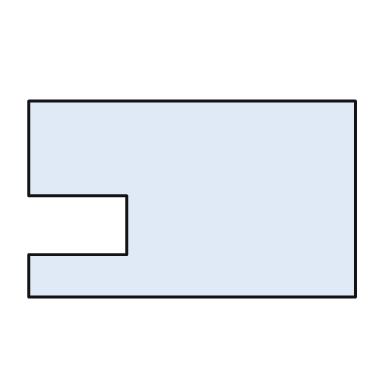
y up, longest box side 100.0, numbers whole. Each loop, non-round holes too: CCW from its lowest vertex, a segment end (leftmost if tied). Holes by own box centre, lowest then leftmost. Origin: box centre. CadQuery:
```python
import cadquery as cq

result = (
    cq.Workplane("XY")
    .moveTo(-50.0, -30.0)
    .lineTo(50.0, -30.0)
    .lineTo(50.0, 30.0)
    .lineTo(-50.0, 30.0)
    .lineTo(-50.0, 1.0)
    .lineTo(-20.0, 1.0)
    .lineTo(-20.0, -17.0)
    .lineTo(-50.0, -17.0)
    .close()
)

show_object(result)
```